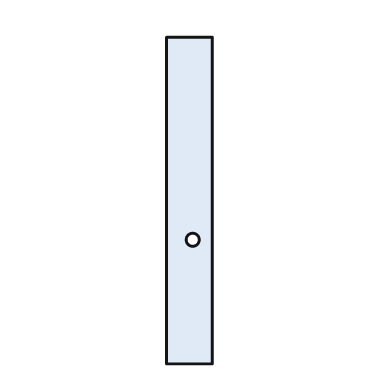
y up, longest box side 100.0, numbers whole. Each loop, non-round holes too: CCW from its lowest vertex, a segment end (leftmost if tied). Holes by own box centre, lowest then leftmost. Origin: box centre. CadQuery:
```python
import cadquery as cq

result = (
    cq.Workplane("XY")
    .moveTo(-7.0, -50.0)
    .lineTo(7.0, -50.0)
    .lineTo(7.0, 50.0)
    .lineTo(-7.0, 50.0)
    .close()
    .moveTo(1.0, -12.0)
    .circle(2.0)
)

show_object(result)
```